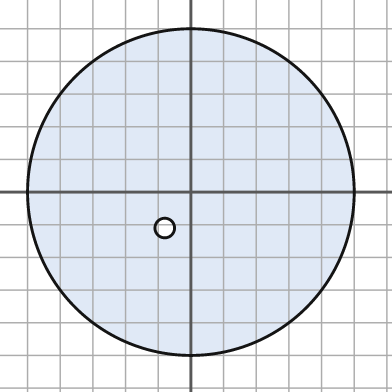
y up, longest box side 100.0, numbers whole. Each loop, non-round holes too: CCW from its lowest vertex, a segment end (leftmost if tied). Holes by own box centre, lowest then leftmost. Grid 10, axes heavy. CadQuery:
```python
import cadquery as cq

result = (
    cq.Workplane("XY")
    .moveTo(0.0, 0.0)
    .circle(50.0)
    .moveTo(-8.0, -11.0)
    .circle(3.0)
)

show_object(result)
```